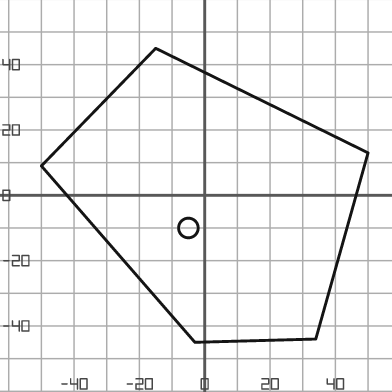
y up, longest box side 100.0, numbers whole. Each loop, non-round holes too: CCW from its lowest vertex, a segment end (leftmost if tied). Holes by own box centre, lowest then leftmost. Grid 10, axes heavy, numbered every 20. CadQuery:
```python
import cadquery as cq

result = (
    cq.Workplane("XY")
    .moveTo(-3.0, -45.0)
    .lineTo(34.0, -44.0)
    .lineTo(50.0, 13.0)
    .lineTo(-15.0, 45.0)
    .lineTo(-50.0, 9.0)
    .close()
    .moveTo(-5.0, -10.0)
    .circle(3.0)
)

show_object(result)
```